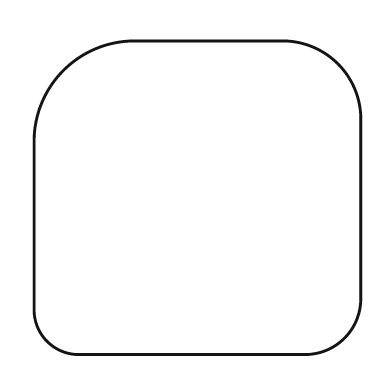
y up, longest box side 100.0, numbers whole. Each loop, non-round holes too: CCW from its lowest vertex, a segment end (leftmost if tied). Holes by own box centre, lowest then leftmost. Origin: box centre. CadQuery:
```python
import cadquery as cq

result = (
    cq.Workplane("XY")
    .moveTo(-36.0, -48.0)
    .lineTo(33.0, -48.0)
    .threePointArc((45.0, -43.0), (50.0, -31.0))
    .lineTo(50.0, 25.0)
    .threePointArc((43.0, 41.0), (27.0, 48.0))
    .lineTo(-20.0, 48.0)
    .threePointArc((-41.0, 39.0), (-50.0, 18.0))
    .lineTo(-50.0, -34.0)
    .threePointArc((-46.0, -44.0), (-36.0, -48.0))
    .close()
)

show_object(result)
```